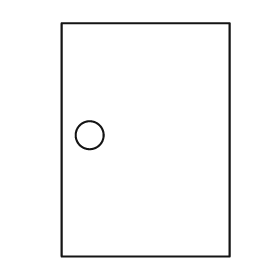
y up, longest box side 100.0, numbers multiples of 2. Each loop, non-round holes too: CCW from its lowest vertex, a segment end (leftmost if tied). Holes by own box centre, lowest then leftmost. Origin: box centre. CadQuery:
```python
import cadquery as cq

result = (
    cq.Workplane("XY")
    .moveTo(-36.0, -50.0)
    .lineTo(36.0, -50.0)
    .lineTo(36.0, 50.0)
    .lineTo(-36.0, 50.0)
    .close()
    .moveTo(-24.0, 2.0)
    .circle(6.0)
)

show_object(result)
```